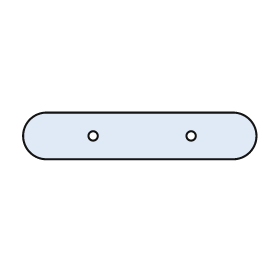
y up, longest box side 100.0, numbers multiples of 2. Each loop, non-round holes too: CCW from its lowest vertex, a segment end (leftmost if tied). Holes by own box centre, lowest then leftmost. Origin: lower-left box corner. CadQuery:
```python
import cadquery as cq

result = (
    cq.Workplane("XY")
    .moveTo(10.0, 0.0)
    .lineTo(90.0, 0.0)
    .threePointArc((100.0, 10.0), (90.0, 20.0))
    .lineTo(10.0, 20.0)
    .threePointArc((0.0, 10.0), (10.0, 0.0))
    .close()
    .moveTo(30.0, 10.0)
    .circle(2.0)
    .moveTo(72.0, 10.0)
    .circle(2.0)
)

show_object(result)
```